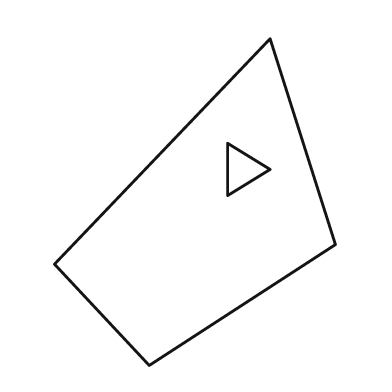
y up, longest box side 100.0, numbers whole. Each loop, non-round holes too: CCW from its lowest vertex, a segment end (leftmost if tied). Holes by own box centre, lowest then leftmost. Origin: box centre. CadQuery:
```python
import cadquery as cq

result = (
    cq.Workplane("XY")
    .moveTo(-14.0, -50.0)
    .lineTo(43.0, -13.0)
    .lineTo(23.0, 50.0)
    .lineTo(-43.0, -19.0)
    .close()
    .moveTo(10.0, 2.0)
    .lineTo(23.0, 10.0)
    .lineTo(10.0, 18.0)
    .close()
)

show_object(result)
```